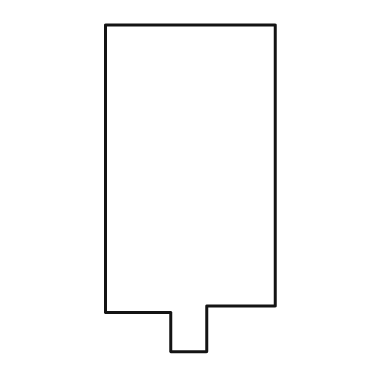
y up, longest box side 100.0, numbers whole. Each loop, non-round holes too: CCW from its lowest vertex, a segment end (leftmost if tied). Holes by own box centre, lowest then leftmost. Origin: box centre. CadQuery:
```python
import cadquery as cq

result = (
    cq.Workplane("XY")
    .moveTo(-6.0, -50.0)
    .lineTo(5.0, -50.0)
    .lineTo(5.0, -36.0)
    .lineTo(26.0, -36.0)
    .lineTo(26.0, 50.0)
    .lineTo(-26.0, 50.0)
    .lineTo(-26.0, -38.0)
    .lineTo(-6.0, -38.0)
    .close()
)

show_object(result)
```